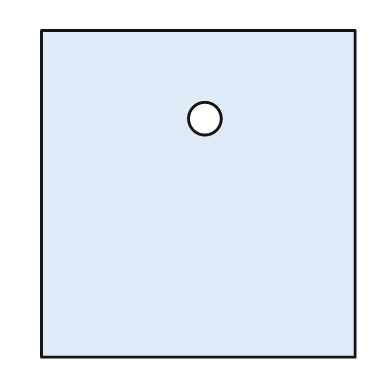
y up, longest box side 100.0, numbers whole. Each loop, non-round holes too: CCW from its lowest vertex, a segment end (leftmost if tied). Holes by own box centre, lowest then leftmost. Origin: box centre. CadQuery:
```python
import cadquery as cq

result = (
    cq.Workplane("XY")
    .moveTo(-48.0, -50.0)
    .lineTo(48.0, -50.0)
    .lineTo(48.0, 50.0)
    .lineTo(-48.0, 50.0)
    .close()
    .moveTo(2.0, 23.0)
    .circle(5.0)
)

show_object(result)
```